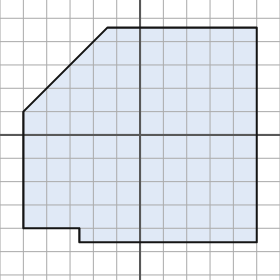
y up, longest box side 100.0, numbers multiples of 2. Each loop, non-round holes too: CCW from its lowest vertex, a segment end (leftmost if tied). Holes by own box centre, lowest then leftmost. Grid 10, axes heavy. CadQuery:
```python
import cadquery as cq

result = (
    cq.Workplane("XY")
    .moveTo(-26.0, -46.0)
    .lineTo(50.0, -46.0)
    .lineTo(50.0, 46.0)
    .lineTo(-14.0, 46.0)
    .lineTo(-50.0, 10.0)
    .lineTo(-50.0, -40.0)
    .lineTo(-26.0, -40.0)
    .close()
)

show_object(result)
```